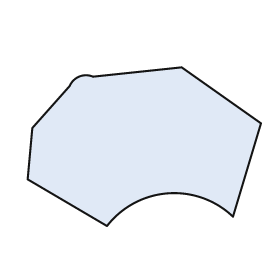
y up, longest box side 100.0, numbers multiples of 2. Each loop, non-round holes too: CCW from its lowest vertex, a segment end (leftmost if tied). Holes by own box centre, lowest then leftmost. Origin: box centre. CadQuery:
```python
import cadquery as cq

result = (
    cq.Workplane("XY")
    .moveTo(-16.0, -34.0)
    .threePointArc((10.0, -20.0), (38.0, -30.0))
    .lineTo(50.0, 10.0)
    .lineTo(16.0, 34.0)
    .lineTo(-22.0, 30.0)
    .threePointArc((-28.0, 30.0), (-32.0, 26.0))
    .lineTo(-48.0, 8.0)
    .lineTo(-50.0, -14.0)
    .close()
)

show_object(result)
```